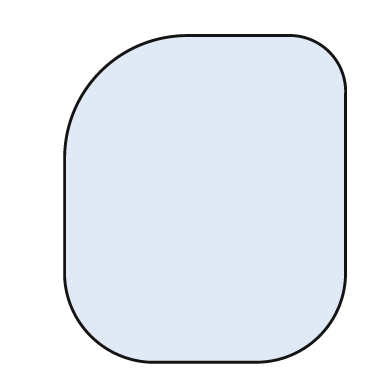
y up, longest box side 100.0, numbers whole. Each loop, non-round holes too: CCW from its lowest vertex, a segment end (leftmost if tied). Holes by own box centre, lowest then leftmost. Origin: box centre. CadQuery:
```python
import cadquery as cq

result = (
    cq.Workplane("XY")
    .moveTo(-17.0, -50.0)
    .lineTo(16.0, -50.0)
    .threePointArc((35.0, -42.0), (43.0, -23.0))
    .lineTo(43.0, 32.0)
    .threePointArc((38.0, 45.0), (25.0, 50.0))
    .lineTo(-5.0, 50.0)
    .threePointArc((-32.0, 39.0), (-43.0, 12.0))
    .lineTo(-43.0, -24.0)
    .threePointArc((-35.0, -42.0), (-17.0, -50.0))
    .close()
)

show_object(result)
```